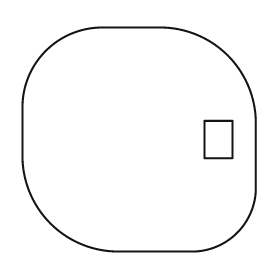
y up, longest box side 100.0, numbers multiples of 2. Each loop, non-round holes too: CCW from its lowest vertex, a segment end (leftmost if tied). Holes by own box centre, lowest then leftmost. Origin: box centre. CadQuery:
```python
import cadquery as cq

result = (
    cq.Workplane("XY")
    .moveTo(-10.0, -48.0)
    .lineTo(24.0, -48.0)
    .threePointArc((42.0, -40.0), (50.0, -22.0))
    .lineTo(50.0, 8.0)
    .threePointArc((38.0, 36.0), (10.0, 48.0))
    .lineTo(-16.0, 48.0)
    .threePointArc((-40.0, 38.0), (-50.0, 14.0))
    .lineTo(-50.0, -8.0)
    .threePointArc((-38.0, -36.0), (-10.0, -48.0))
    .close()
    .moveTo(28.0, -8.0)
    .lineTo(40.0, -8.0)
    .lineTo(40.0, 8.0)
    .lineTo(28.0, 8.0)
    .close()
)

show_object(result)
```